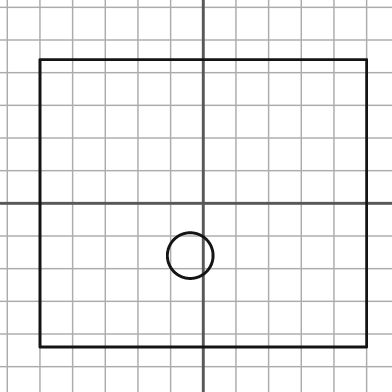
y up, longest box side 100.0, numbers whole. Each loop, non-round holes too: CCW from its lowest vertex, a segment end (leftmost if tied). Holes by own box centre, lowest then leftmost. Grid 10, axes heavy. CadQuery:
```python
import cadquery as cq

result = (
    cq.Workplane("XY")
    .moveTo(-50.0, -44.0)
    .lineTo(50.0, -44.0)
    .lineTo(50.0, 44.0)
    .lineTo(-50.0, 44.0)
    .close()
    .moveTo(-4.0, -16.0)
    .circle(7.0)
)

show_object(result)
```